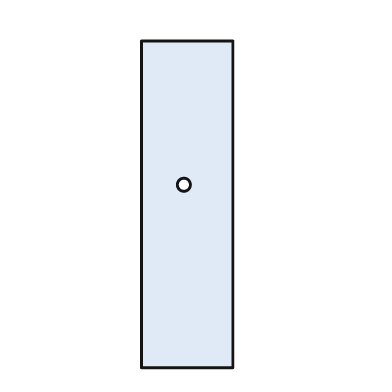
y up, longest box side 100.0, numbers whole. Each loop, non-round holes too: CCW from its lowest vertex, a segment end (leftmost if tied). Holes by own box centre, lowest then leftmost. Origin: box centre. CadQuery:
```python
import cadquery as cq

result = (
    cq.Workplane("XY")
    .moveTo(-14.0, -50.0)
    .lineTo(14.0, -50.0)
    .lineTo(14.0, 50.0)
    .lineTo(-14.0, 50.0)
    .close()
    .moveTo(-1.0, 6.0)
    .circle(2.0)
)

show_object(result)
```